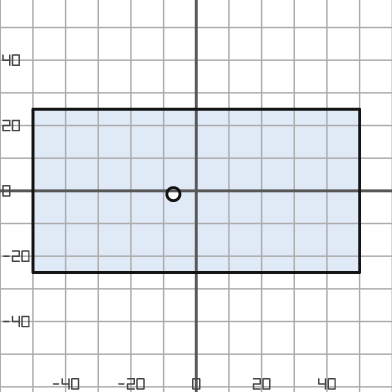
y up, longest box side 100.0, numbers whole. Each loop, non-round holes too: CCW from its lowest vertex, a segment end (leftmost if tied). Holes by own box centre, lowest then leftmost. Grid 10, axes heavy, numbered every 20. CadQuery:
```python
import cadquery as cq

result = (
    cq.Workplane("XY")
    .moveTo(-50.0, -25.0)
    .lineTo(50.0, -25.0)
    .lineTo(50.0, 25.0)
    .lineTo(-50.0, 25.0)
    .close()
    .moveTo(-7.0, -1.0)
    .circle(2.0)
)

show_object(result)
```